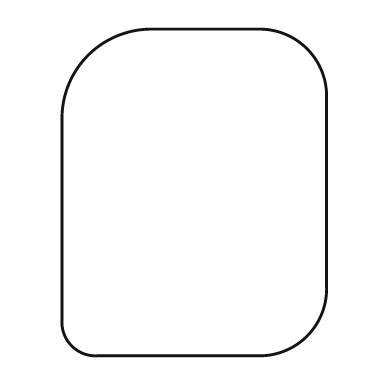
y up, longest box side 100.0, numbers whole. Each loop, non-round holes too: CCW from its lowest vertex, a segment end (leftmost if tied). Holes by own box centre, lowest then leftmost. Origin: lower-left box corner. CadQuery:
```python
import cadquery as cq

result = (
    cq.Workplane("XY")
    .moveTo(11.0, 0.0)
    .lineTo(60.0, 0.0)
    .threePointArc((75.0, 6.0), (81.0, 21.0))
    .lineTo(81.0, 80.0)
    .threePointArc((75.0, 94.0), (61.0, 100.0))
    .lineTo(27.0, 100.0)
    .threePointArc((8.0, 92.0), (0.0, 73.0))
    .lineTo(0.0, 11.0)
    .threePointArc((3.0, 3.0), (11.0, 0.0))
    .close()
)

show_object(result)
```